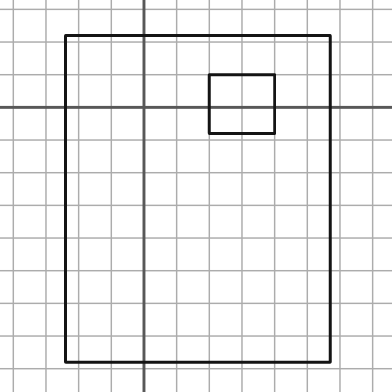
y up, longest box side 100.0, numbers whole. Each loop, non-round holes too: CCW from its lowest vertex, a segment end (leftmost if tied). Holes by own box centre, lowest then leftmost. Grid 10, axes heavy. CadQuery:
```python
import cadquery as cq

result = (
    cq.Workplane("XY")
    .moveTo(-24.0, -78.0)
    .lineTo(57.0, -78.0)
    .lineTo(57.0, 22.0)
    .lineTo(-24.0, 22.0)
    .close()
    .moveTo(20.0, -8.0)
    .lineTo(40.0, -8.0)
    .lineTo(40.0, 10.0)
    .lineTo(20.0, 10.0)
    .close()
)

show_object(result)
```